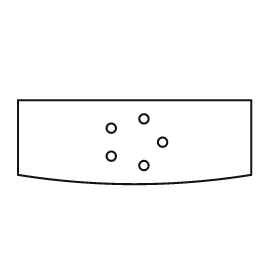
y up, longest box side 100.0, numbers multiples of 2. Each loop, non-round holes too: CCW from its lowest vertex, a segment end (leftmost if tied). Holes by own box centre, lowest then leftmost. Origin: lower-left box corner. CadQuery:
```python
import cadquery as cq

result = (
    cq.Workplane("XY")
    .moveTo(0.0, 4.0)
    .threePointArc((50.0, 0.0), (100.0, 4.0))
    .lineTo(100.0, 36.0)
    .lineTo(0.0, 36.0)
    .close()
    .moveTo(54.0, 8.0)
    .circle(2.0)
    .moveTo(40.0, 12.0)
    .circle(2.0)
    .moveTo(62.0, 18.0)
    .circle(2.0)
    .moveTo(40.0, 24.0)
    .circle(2.0)
    .moveTo(54.0, 28.0)
    .circle(2.0)
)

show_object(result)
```